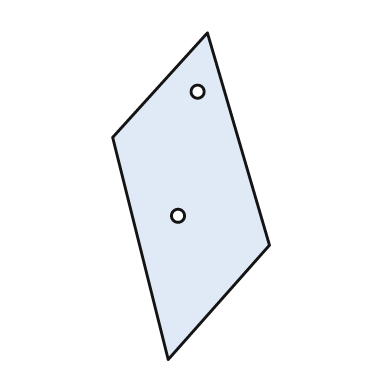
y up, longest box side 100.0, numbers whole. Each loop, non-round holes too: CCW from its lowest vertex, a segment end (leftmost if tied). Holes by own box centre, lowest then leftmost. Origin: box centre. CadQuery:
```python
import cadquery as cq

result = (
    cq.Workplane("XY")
    .moveTo(-7.0, -50.0)
    .lineTo(24.0, -15.0)
    .lineTo(5.0, 50.0)
    .lineTo(-24.0, 18.0)
    .close()
    .moveTo(-4.0, -6.0)
    .circle(2.0)
    .moveTo(2.0, 32.0)
    .circle(2.0)
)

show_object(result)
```